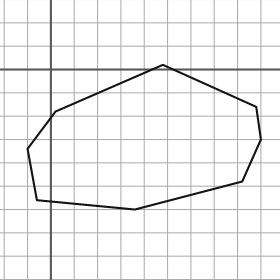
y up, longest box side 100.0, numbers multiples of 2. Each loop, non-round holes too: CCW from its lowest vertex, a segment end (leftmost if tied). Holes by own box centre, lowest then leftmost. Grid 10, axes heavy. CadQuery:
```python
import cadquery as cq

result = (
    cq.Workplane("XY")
    .moveTo(36.0, -60.0)
    .lineTo(82.0, -48.0)
    .lineTo(90.0, -30.0)
    .lineTo(88.0, -16.0)
    .lineTo(48.0, 2.0)
    .lineTo(2.0, -18.0)
    .lineTo(-10.0, -34.0)
    .lineTo(-6.0, -56.0)
    .close()
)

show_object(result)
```